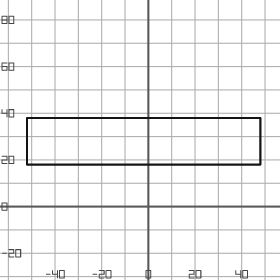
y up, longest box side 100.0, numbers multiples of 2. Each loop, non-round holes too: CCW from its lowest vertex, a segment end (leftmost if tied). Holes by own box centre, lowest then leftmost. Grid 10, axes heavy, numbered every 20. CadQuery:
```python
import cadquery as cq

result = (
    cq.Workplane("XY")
    .moveTo(-52.0, 18.0)
    .lineTo(48.0, 18.0)
    .lineTo(48.0, 38.0)
    .lineTo(-52.0, 38.0)
    .close()
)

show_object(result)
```